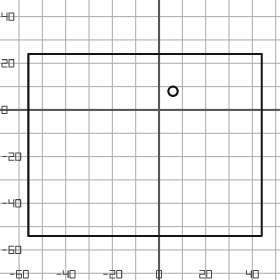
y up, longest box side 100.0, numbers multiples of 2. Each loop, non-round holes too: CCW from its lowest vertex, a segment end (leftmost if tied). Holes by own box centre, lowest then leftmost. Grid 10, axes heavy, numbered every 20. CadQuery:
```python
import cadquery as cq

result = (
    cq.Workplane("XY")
    .moveTo(-56.0, -54.0)
    .lineTo(44.0, -54.0)
    .lineTo(44.0, 24.0)
    .lineTo(-56.0, 24.0)
    .close()
    .moveTo(6.0, 8.0)
    .circle(2.0)
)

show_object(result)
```